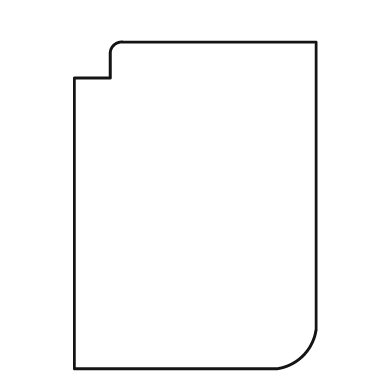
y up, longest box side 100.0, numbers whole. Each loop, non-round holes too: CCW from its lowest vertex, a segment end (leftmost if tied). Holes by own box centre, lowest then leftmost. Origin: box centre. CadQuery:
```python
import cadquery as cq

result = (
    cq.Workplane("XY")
    .moveTo(-37.0, -50.0)
    .lineTo(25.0, -50.0)
    .threePointArc((33.0, -46.0), (37.0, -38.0))
    .lineTo(37.0, 50.0)
    .lineTo(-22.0, 50.0)
    .threePointArc((-25.0, 49.0), (-26.0, 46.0))
    .lineTo(-26.0, 39.0)
    .lineTo(-37.0, 39.0)
    .close()
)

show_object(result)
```